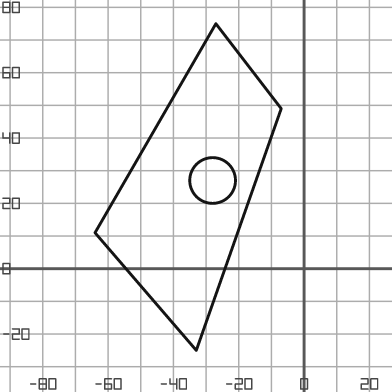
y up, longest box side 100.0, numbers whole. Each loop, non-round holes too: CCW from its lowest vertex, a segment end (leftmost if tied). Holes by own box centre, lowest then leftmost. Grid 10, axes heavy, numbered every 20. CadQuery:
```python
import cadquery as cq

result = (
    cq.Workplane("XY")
    .moveTo(-33.0, -25.0)
    .lineTo(-7.0, 49.0)
    .lineTo(-27.0, 75.0)
    .lineTo(-64.0, 11.0)
    .close()
    .moveTo(-28.0, 27.0)
    .circle(7.0)
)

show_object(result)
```